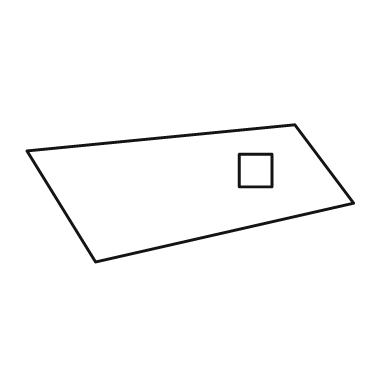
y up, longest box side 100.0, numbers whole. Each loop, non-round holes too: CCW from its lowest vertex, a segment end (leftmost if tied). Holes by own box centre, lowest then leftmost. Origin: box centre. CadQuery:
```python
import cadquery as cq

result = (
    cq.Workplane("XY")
    .moveTo(-29.0, -21.0)
    .lineTo(50.0, -3.0)
    .lineTo(32.0, 21.0)
    .lineTo(-50.0, 13.0)
    .close()
    .moveTo(15.0, 2.0)
    .lineTo(25.0, 2.0)
    .lineTo(25.0, 12.0)
    .lineTo(15.0, 12.0)
    .close()
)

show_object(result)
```